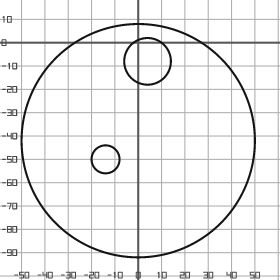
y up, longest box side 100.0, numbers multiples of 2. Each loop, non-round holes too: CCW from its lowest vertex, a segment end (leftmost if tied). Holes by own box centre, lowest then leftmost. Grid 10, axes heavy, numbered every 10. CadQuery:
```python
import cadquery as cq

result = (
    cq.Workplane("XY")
    .moveTo(0.0, -42.0)
    .circle(50.0)
    .moveTo(-14.0, -50.0)
    .circle(6.0)
    .moveTo(4.0, -8.0)
    .circle(10.0)
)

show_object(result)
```